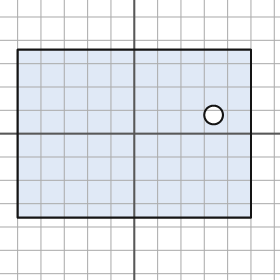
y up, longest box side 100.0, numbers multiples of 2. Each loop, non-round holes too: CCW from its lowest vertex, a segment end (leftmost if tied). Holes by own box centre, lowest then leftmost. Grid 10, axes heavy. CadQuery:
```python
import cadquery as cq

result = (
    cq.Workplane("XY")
    .moveTo(-50.0, -36.0)
    .lineTo(50.0, -36.0)
    .lineTo(50.0, 36.0)
    .lineTo(-50.0, 36.0)
    .close()
    .moveTo(34.0, 8.0)
    .circle(4.0)
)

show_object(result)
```